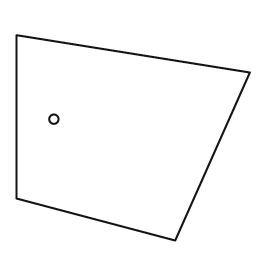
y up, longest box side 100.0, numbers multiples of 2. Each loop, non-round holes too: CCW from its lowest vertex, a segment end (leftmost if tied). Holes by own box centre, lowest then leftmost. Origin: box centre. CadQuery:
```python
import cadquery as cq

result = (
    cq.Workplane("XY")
    .moveTo(18.0, -44.0)
    .lineTo(50.0, 28.0)
    .lineTo(-50.0, 44.0)
    .lineTo(-50.0, -26.0)
    .close()
    .moveTo(-34.0, 8.0)
    .circle(2.0)
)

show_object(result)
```